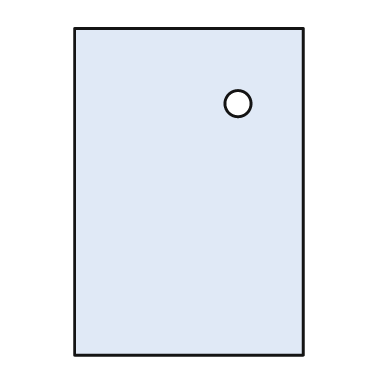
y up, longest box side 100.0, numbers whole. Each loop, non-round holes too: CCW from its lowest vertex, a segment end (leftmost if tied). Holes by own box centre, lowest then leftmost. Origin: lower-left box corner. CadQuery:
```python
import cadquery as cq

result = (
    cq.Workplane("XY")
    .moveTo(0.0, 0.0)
    .lineTo(70.0, 0.0)
    .lineTo(70.0, 100.0)
    .lineTo(0.0, 100.0)
    .close()
    .moveTo(50.0, 77.0)
    .circle(4.0)
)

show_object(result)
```